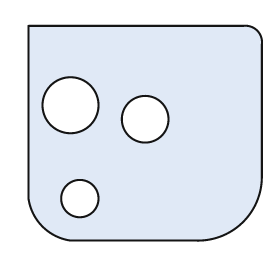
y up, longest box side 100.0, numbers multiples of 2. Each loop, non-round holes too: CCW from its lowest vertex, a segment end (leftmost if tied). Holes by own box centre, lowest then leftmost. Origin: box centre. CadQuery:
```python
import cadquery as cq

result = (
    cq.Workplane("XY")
    .moveTo(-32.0, -46.0)
    .lineTo(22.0, -46.0)
    .threePointArc((42.0, -38.0), (50.0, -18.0))
    .lineTo(50.0, 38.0)
    .threePointArc((48.0, 44.0), (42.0, 46.0))
    .lineTo(-50.0, 46.0)
    .lineTo(-50.0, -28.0)
    .threePointArc((-44.0, -40.0), (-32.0, -46.0))
    .close()
    .moveTo(-28.0, -28.0)
    .circle(8.0)
    .moveTo(0.0, 6.0)
    .circle(10.0)
    .moveTo(-32.0, 12.0)
    .circle(12.0)
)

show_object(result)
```